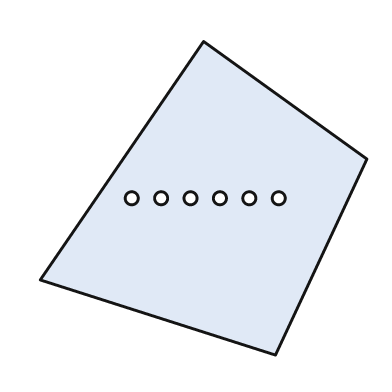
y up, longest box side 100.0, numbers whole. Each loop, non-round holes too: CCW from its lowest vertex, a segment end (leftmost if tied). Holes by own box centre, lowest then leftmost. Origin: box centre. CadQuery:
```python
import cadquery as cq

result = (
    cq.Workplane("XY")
    .moveTo(22.0, -48.0)
    .lineTo(50.0, 12.0)
    .lineTo(0.0, 48.0)
    .lineTo(-50.0, -25.0)
    .close()
    .moveTo(-22.0, 0.0)
    .circle(2.0)
    .moveTo(-13.0, 0.0)
    .circle(2.0)
    .moveTo(-4.0, 0.0)
    .circle(2.0)
    .moveTo(5.0, 0.0)
    .circle(2.0)
    .moveTo(14.0, 0.0)
    .circle(2.0)
    .moveTo(23.0, 0.0)
    .circle(2.0)
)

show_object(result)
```